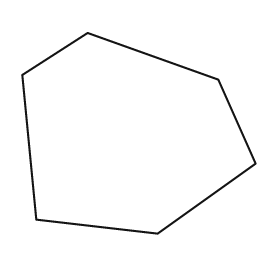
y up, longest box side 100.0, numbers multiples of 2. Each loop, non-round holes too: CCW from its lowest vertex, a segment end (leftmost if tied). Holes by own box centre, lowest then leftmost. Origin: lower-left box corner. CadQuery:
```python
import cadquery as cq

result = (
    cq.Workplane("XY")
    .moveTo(58.0, 0.0)
    .lineTo(100.0, 30.0)
    .lineTo(84.0, 66.0)
    .lineTo(28.0, 86.0)
    .lineTo(0.0, 68.0)
    .lineTo(6.0, 6.0)
    .close()
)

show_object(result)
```